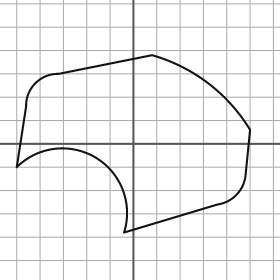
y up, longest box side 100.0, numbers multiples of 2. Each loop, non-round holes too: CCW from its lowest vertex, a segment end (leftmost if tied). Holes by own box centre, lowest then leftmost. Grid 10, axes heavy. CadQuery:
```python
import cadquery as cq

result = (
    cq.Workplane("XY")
    .moveTo(-4.0, -38.0)
    .lineTo(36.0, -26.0)
    .threePointArc((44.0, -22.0), (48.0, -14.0))
    .lineTo(50.0, 6.0)
    .threePointArc((32.0, 26.0), (8.0, 38.0))
    .lineTo(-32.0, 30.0)
    .threePointArc((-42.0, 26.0), (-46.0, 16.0))
    .lineTo(-50.0, -10.0)
    .threePointArc((-16.0, -6.0), (-4.0, -38.0))
    .close()
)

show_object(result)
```